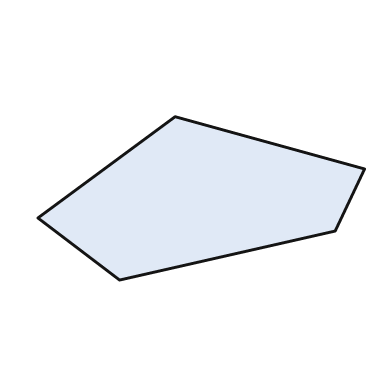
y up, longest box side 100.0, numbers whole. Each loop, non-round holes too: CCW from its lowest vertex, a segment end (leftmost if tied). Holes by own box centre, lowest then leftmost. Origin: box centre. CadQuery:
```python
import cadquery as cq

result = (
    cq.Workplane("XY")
    .moveTo(-25.0, -25.0)
    .lineTo(41.0, -10.0)
    .lineTo(50.0, 9.0)
    .lineTo(-8.0, 25.0)
    .lineTo(-50.0, -6.0)
    .close()
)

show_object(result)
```